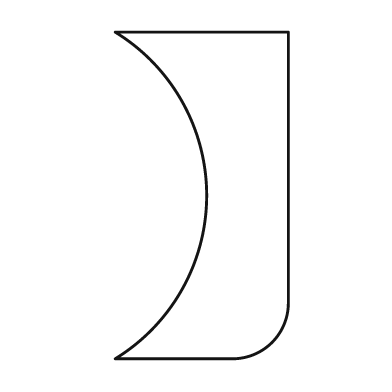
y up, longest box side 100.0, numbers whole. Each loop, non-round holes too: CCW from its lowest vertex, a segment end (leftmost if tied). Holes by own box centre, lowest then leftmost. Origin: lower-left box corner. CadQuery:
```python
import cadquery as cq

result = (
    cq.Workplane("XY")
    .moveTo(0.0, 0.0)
    .lineTo(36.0, 0.0)
    .threePointArc((48.0, 5.0), (53.0, 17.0))
    .lineTo(53.0, 100.0)
    .lineTo(0.0, 100.0)
    .threePointArc((28.0, 50.0), (0.0, 0.0))
    .close()
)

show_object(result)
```